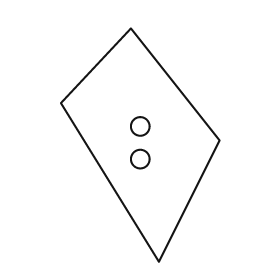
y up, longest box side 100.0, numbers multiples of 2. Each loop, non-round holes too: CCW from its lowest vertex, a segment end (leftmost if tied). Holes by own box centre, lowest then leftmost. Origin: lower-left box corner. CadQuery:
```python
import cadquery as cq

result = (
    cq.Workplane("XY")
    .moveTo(42.0, 0.0)
    .lineTo(68.0, 52.0)
    .lineTo(30.0, 100.0)
    .lineTo(0.0, 68.0)
    .close()
    .moveTo(34.0, 44.0)
    .circle(4.0)
    .moveTo(34.0, 58.0)
    .circle(4.0)
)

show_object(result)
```